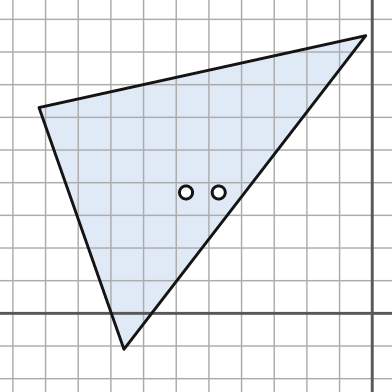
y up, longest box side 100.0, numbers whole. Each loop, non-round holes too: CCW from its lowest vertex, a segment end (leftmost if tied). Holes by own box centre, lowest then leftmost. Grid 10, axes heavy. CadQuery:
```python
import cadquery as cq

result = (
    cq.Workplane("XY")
    .moveTo(-76.0, -11.0)
    .lineTo(-2.0, 85.0)
    .lineTo(-102.0, 63.0)
    .close()
    .moveTo(-57.0, 37.0)
    .circle(2.0)
    .moveTo(-47.0, 37.0)
    .circle(2.0)
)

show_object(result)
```